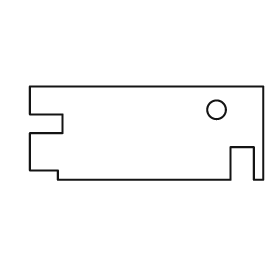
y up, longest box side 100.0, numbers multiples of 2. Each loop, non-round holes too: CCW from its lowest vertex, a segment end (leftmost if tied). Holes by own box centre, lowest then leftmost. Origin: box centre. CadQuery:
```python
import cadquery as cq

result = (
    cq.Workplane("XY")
    .moveTo(-38.0, -20.0)
    .lineTo(36.0, -20.0)
    .lineTo(36.0, -6.0)
    .lineTo(46.0, -6.0)
    .lineTo(46.0, -20.0)
    .lineTo(50.0, -20.0)
    .lineTo(50.0, 20.0)
    .lineTo(-50.0, 20.0)
    .lineTo(-50.0, 8.0)
    .lineTo(-36.0, 8.0)
    .lineTo(-36.0, 0.0)
    .lineTo(-50.0, 0.0)
    .lineTo(-50.0, -16.0)
    .lineTo(-38.0, -16.0)
    .close()
    .moveTo(30.0, 10.0)
    .circle(4.0)
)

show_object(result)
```